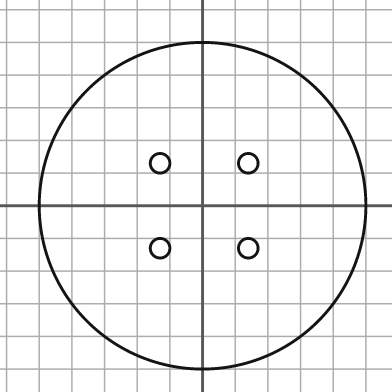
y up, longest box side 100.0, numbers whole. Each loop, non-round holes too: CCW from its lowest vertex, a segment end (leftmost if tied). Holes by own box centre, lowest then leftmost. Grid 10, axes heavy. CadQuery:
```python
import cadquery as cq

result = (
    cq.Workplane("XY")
    .moveTo(0.0, 0.0)
    .circle(50.0)
    .moveTo(-13.0, -13.0)
    .circle(3.0)
    .moveTo(14.0, -13.0)
    .circle(3.0)
    .moveTo(-13.0, 13.0)
    .circle(3.0)
    .moveTo(14.0, 13.0)
    .circle(3.0)
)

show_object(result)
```